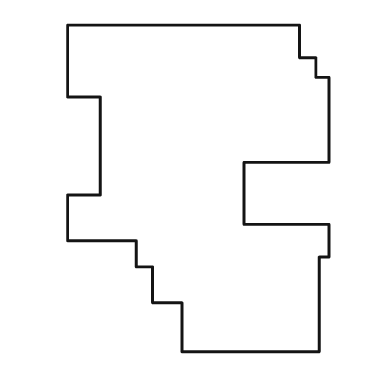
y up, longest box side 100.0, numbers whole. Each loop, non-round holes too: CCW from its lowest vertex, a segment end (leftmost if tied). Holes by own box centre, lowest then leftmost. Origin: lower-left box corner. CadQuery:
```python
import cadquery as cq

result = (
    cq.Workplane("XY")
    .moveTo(35.0, 0.0)
    .lineTo(77.0, 0.0)
    .lineTo(77.0, 29.0)
    .lineTo(80.0, 29.0)
    .lineTo(80.0, 39.0)
    .lineTo(54.0, 39.0)
    .lineTo(54.0, 58.0)
    .lineTo(80.0, 58.0)
    .lineTo(80.0, 84.0)
    .lineTo(76.0, 84.0)
    .lineTo(76.0, 90.0)
    .lineTo(71.0, 90.0)
    .lineTo(71.0, 100.0)
    .lineTo(0.0, 100.0)
    .lineTo(0.0, 78.0)
    .lineTo(10.0, 78.0)
    .lineTo(10.0, 48.0)
    .lineTo(0.0, 48.0)
    .lineTo(0.0, 34.0)
    .lineTo(21.0, 34.0)
    .lineTo(21.0, 26.0)
    .lineTo(26.0, 26.0)
    .lineTo(26.0, 15.0)
    .lineTo(35.0, 15.0)
    .close()
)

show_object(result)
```